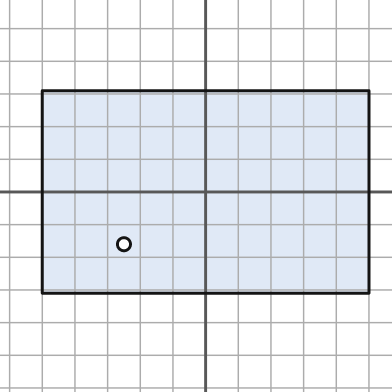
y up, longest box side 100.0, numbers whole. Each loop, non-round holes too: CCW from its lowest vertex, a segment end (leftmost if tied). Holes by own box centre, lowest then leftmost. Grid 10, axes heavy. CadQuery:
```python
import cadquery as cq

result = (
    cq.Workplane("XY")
    .moveTo(-50.0, -31.0)
    .lineTo(50.0, -31.0)
    .lineTo(50.0, 31.0)
    .lineTo(-50.0, 31.0)
    .close()
    .moveTo(-25.0, -16.0)
    .circle(2.0)
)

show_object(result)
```